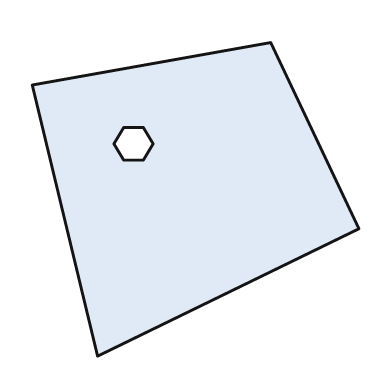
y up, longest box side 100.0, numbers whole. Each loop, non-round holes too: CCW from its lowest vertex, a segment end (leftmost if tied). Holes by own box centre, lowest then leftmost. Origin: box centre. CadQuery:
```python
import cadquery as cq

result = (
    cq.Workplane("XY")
    .moveTo(-30.0, -48.0)
    .lineTo(50.0, -9.0)
    .lineTo(23.0, 48.0)
    .lineTo(-50.0, 35.0)
    .close()
    .moveTo(-22.0, 12.0)
    .lineTo(-16.0, 12.0)
    .lineTo(-13.0, 17.0)
    .lineTo(-16.0, 22.0)
    .lineTo(-22.0, 22.0)
    .lineTo(-25.0, 17.0)
    .close()
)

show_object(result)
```